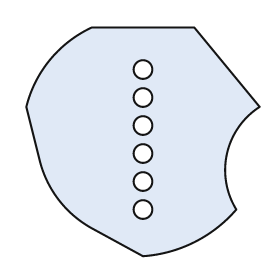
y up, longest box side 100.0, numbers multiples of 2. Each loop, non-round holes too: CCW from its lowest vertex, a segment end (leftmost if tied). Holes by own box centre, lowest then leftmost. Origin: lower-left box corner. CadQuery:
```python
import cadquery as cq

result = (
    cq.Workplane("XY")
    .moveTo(50.0, 0.0)
    .threePointArc((72.0, 6.0), (90.0, 20.0))
    .threePointArc((86.0, 44.0), (100.0, 64.0))
    .lineTo(72.0, 98.0)
    .lineTo(28.0, 98.0)
    .threePointArc((10.0, 84.0), (0.0, 64.0))
    .lineTo(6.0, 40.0)
    .threePointArc((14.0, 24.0), (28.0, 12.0))
    .close()
    .moveTo(50.0, 20.0)
    .circle(4.0)
    .moveTo(50.0, 32.0)
    .circle(4.0)
    .moveTo(50.0, 44.0)
    .circle(4.0)
    .moveTo(50.0, 56.0)
    .circle(4.0)
    .moveTo(50.0, 68.0)
    .circle(4.0)
    .moveTo(50.0, 80.0)
    .circle(4.0)
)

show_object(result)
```